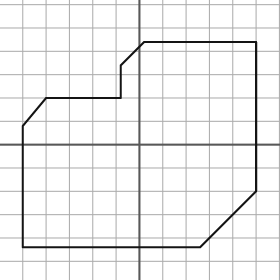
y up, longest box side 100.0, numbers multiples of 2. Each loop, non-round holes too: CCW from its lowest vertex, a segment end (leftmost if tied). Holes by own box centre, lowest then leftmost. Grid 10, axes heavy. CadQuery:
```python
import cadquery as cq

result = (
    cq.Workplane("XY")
    .moveTo(-50.0, -44.0)
    .lineTo(26.0, -44.0)
    .lineTo(50.0, -20.0)
    .lineTo(50.0, 44.0)
    .lineTo(2.0, 44.0)
    .lineTo(-8.0, 34.0)
    .lineTo(-8.0, 20.0)
    .lineTo(-40.0, 20.0)
    .lineTo(-50.0, 8.0)
    .close()
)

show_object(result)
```